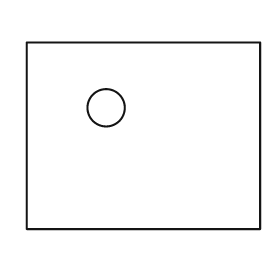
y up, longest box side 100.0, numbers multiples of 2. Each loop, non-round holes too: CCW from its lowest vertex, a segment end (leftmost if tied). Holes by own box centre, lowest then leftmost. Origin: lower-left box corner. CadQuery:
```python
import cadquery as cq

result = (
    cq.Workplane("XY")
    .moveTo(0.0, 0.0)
    .lineTo(100.0, 0.0)
    .lineTo(100.0, 80.0)
    .lineTo(0.0, 80.0)
    .close()
    .moveTo(34.0, 52.0)
    .circle(8.0)
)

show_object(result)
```